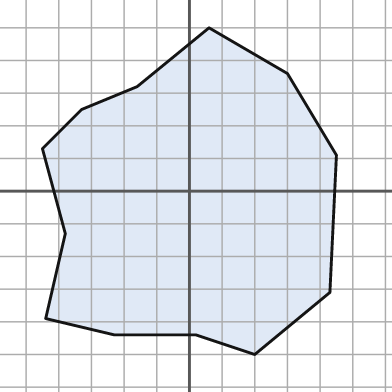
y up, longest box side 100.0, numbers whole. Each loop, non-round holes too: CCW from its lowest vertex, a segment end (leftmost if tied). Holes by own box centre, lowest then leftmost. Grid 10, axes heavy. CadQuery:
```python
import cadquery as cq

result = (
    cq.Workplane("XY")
    .moveTo(20.0, -50.0)
    .lineTo(43.0, -31.0)
    .lineTo(45.0, 11.0)
    .lineTo(30.0, 36.0)
    .lineTo(6.0, 50.0)
    .lineTo(-16.0, 32.0)
    .lineTo(-33.0, 25.0)
    .lineTo(-45.0, 13.0)
    .lineTo(-38.0, -13.0)
    .lineTo(-44.0, -39.0)
    .lineTo(-23.0, -44.0)
    .lineTo(2.0, -44.0)
    .close()
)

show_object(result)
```